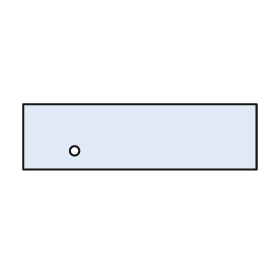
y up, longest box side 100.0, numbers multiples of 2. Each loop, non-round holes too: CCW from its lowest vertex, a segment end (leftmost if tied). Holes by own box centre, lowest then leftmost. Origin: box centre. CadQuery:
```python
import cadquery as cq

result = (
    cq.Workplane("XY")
    .moveTo(-50.0, -14.0)
    .lineTo(50.0, -14.0)
    .lineTo(50.0, 14.0)
    .lineTo(-50.0, 14.0)
    .close()
    .moveTo(-28.0, -6.0)
    .circle(2.0)
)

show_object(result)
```